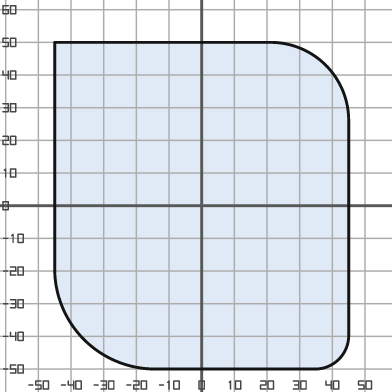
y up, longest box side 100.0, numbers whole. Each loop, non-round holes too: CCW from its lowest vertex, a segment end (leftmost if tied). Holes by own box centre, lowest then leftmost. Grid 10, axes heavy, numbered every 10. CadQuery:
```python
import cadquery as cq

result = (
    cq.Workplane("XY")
    .moveTo(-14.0, -50.0)
    .lineTo(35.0, -50.0)
    .threePointArc((42.0, -47.0), (45.0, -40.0))
    .lineTo(45.0, 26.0)
    .threePointArc((38.0, 43.0), (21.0, 50.0))
    .lineTo(-45.0, 50.0)
    .lineTo(-45.0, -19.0)
    .threePointArc((-36.0, -41.0), (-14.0, -50.0))
    .close()
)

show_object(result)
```